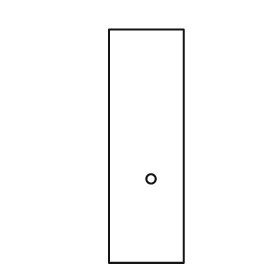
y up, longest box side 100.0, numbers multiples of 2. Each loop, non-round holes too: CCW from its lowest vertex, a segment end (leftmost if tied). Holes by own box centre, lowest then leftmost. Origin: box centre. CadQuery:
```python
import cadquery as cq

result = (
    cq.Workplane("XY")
    .moveTo(-16.0, -50.0)
    .lineTo(16.0, -50.0)
    .lineTo(16.0, 50.0)
    .lineTo(-16.0, 50.0)
    .close()
    .moveTo(2.0, -14.0)
    .circle(2.0)
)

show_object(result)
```